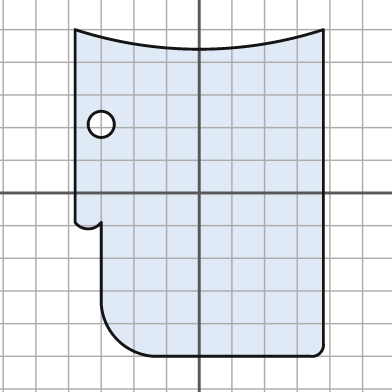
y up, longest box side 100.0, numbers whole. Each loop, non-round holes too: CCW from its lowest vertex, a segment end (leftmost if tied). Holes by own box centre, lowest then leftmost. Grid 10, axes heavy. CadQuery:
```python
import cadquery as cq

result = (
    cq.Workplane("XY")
    .moveTo(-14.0, -50.0)
    .lineTo(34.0, -50.0)
    .threePointArc((37.0, -49.0), (38.0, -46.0))
    .lineTo(38.0, 50.0)
    .threePointArc((0.0, 44.0), (-38.0, 50.0))
    .lineTo(-38.0, -9.0)
    .threePointArc((-34.0, -11.0), (-30.0, -9.0))
    .lineTo(-30.0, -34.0)
    .threePointArc((-25.0, -45.0), (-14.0, -50.0))
    .close()
    .moveTo(-30.0, 21.0)
    .circle(4.0)
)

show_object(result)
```